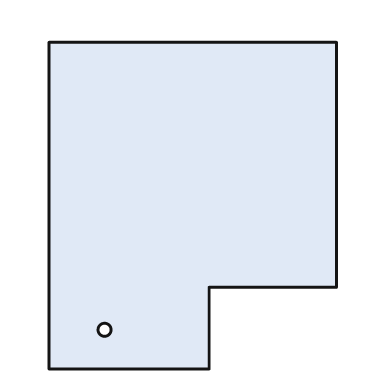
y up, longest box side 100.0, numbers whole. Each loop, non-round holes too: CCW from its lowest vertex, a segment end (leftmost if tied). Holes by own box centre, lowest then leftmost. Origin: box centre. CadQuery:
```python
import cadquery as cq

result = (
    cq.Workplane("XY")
    .moveTo(-44.0, -50.0)
    .lineTo(5.0, -50.0)
    .lineTo(5.0, -25.0)
    .lineTo(44.0, -25.0)
    .lineTo(44.0, 50.0)
    .lineTo(-44.0, 50.0)
    .close()
    .moveTo(-27.0, -38.0)
    .circle(2.0)
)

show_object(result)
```